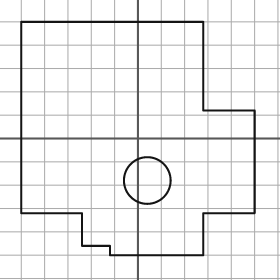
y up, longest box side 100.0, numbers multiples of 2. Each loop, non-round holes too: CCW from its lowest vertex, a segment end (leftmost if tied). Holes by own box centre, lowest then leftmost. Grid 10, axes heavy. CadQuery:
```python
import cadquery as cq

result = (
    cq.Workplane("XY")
    .moveTo(-12.0, -50.0)
    .lineTo(28.0, -50.0)
    .lineTo(28.0, -32.0)
    .lineTo(50.0, -32.0)
    .lineTo(50.0, 12.0)
    .lineTo(28.0, 12.0)
    .lineTo(28.0, 50.0)
    .lineTo(-50.0, 50.0)
    .lineTo(-50.0, -32.0)
    .lineTo(-24.0, -32.0)
    .lineTo(-24.0, -46.0)
    .lineTo(-12.0, -46.0)
    .close()
    .moveTo(4.0, -18.0)
    .circle(10.0)
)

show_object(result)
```